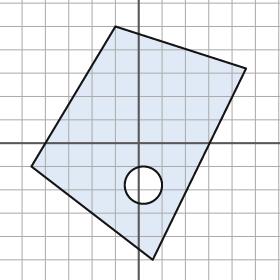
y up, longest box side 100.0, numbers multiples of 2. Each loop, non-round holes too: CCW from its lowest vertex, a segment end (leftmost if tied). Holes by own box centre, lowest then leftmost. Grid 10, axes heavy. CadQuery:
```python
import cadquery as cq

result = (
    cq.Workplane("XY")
    .moveTo(6.0, -50.0)
    .lineTo(46.0, 32.0)
    .lineTo(-10.0, 50.0)
    .lineTo(-46.0, -10.0)
    .close()
    .moveTo(2.0, -18.0)
    .circle(8.0)
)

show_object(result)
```